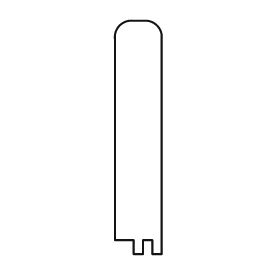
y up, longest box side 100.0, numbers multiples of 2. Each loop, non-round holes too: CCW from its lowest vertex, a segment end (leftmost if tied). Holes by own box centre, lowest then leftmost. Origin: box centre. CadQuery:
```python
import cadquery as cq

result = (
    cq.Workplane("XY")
    .moveTo(-2.0, -50.0)
    .lineTo(2.0, -50.0)
    .lineTo(2.0, -44.0)
    .lineTo(6.0, -44.0)
    .lineTo(6.0, -50.0)
    .lineTo(10.0, -50.0)
    .lineTo(10.0, 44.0)
    .threePointArc((8.0, 48.0), (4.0, 50.0))
    .lineTo(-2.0, 50.0)
    .threePointArc((-8.0, 48.0), (-10.0, 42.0))
    .lineTo(-10.0, -44.0)
    .lineTo(-2.0, -44.0)
    .close()
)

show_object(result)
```